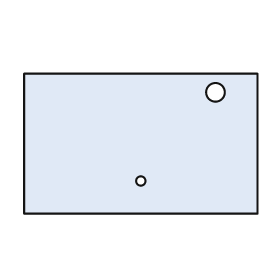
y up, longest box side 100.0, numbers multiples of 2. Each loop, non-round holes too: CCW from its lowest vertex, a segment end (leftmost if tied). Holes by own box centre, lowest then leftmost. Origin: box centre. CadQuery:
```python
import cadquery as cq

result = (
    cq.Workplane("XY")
    .moveTo(-50.0, -30.0)
    .lineTo(50.0, -30.0)
    .lineTo(50.0, 30.0)
    .lineTo(-50.0, 30.0)
    .close()
    .moveTo(0.0, -16.0)
    .circle(2.0)
    .moveTo(32.0, 22.0)
    .circle(4.0)
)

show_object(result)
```